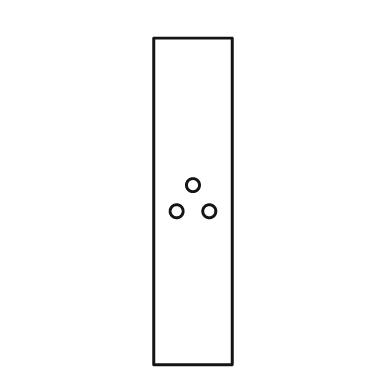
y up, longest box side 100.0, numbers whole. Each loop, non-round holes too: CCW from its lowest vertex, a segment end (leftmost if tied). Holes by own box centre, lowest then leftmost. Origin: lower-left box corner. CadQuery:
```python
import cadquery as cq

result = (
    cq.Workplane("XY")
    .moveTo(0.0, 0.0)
    .lineTo(24.0, 0.0)
    .lineTo(24.0, 100.0)
    .lineTo(0.0, 100.0)
    .close()
    .moveTo(7.0, 47.0)
    .circle(2.0)
    .moveTo(17.0, 47.0)
    .circle(2.0)
    .moveTo(12.0, 55.0)
    .circle(2.0)
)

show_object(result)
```